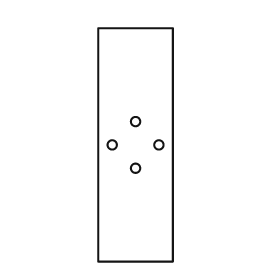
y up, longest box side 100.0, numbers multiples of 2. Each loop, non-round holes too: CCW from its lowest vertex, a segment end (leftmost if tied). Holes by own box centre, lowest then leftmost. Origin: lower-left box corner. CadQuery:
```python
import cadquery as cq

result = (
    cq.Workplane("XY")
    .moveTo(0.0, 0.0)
    .lineTo(32.0, 0.0)
    .lineTo(32.0, 100.0)
    .lineTo(0.0, 100.0)
    .close()
    .moveTo(16.0, 40.0)
    .circle(2.0)
    .moveTo(6.0, 50.0)
    .circle(2.0)
    .moveTo(26.0, 50.0)
    .circle(2.0)
    .moveTo(16.0, 60.0)
    .circle(2.0)
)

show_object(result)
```